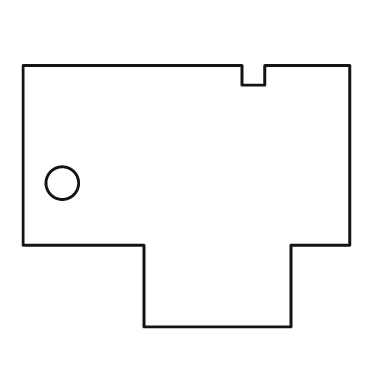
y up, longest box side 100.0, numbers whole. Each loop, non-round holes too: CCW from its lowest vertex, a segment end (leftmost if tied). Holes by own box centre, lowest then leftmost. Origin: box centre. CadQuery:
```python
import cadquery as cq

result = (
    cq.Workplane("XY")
    .moveTo(-13.0, -40.0)
    .lineTo(32.0, -40.0)
    .lineTo(32.0, -15.0)
    .lineTo(50.0, -15.0)
    .lineTo(50.0, 40.0)
    .lineTo(24.0, 40.0)
    .lineTo(24.0, 34.0)
    .lineTo(17.0, 34.0)
    .lineTo(17.0, 40.0)
    .lineTo(-50.0, 40.0)
    .lineTo(-50.0, -15.0)
    .lineTo(-13.0, -15.0)
    .close()
    .moveTo(-38.0, 4.0)
    .circle(5.0)
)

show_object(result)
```